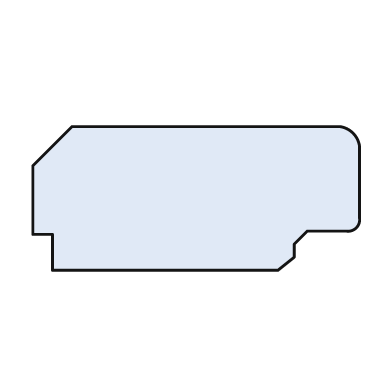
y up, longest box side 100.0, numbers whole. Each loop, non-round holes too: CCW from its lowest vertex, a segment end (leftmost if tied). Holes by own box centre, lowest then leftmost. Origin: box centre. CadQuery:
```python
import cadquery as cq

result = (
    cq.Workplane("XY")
    .moveTo(-44.0, -22.0)
    .lineTo(25.0, -22.0)
    .lineTo(30.0, -18.0)
    .lineTo(30.0, -14.0)
    .lineTo(34.0, -10.0)
    .lineTo(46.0, -10.0)
    .threePointArc((49.0, -9.0), (50.0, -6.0))
    .lineTo(50.0, 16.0)
    .threePointArc((48.0, 20.0), (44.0, 22.0))
    .lineTo(-38.0, 22.0)
    .lineTo(-50.0, 10.0)
    .lineTo(-50.0, -11.0)
    .lineTo(-44.0, -11.0)
    .close()
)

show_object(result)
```